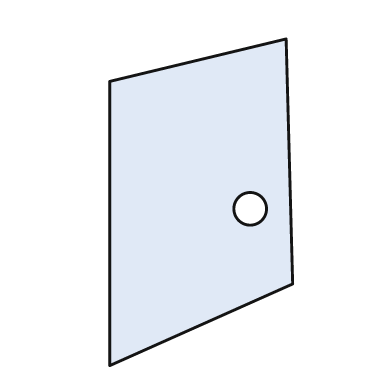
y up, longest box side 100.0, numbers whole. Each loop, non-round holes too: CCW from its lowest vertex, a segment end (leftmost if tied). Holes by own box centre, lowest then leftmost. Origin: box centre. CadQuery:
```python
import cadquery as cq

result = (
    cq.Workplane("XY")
    .moveTo(-28.0, -50.0)
    .lineTo(28.0, -25.0)
    .lineTo(26.0, 50.0)
    .lineTo(-28.0, 37.0)
    .close()
    .moveTo(15.0, -2.0)
    .circle(5.0)
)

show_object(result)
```